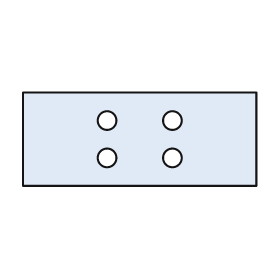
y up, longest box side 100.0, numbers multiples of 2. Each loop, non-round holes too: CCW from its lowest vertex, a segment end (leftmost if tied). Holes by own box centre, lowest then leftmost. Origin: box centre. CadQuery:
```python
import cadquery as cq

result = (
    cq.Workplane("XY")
    .moveTo(-50.0, -20.0)
    .lineTo(50.0, -20.0)
    .lineTo(50.0, 20.0)
    .lineTo(-50.0, 20.0)
    .close()
    .moveTo(-14.0, -8.0)
    .circle(4.0)
    .moveTo(14.0, -8.0)
    .circle(4.0)
    .moveTo(-14.0, 8.0)
    .circle(4.0)
    .moveTo(14.0, 8.0)
    .circle(4.0)
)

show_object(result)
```